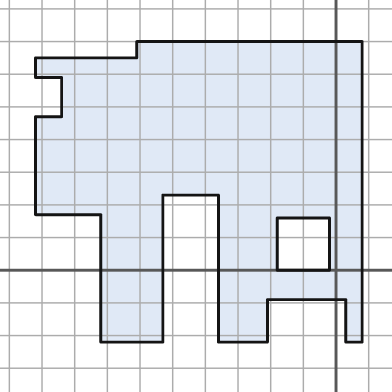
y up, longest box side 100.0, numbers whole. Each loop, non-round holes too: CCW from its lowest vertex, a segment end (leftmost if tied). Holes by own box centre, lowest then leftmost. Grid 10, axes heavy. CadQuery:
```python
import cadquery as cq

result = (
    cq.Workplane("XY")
    .moveTo(-72.0, -22.0)
    .lineTo(-53.0, -22.0)
    .lineTo(-53.0, 23.0)
    .lineTo(-36.0, 23.0)
    .lineTo(-36.0, -22.0)
    .lineTo(-21.0, -22.0)
    .lineTo(-21.0, -9.0)
    .lineTo(3.0, -9.0)
    .lineTo(3.0, -22.0)
    .lineTo(8.0, -22.0)
    .lineTo(8.0, 70.0)
    .lineTo(-61.0, 70.0)
    .lineTo(-61.0, 65.0)
    .lineTo(-92.0, 65.0)
    .lineTo(-92.0, 59.0)
    .lineTo(-84.0, 59.0)
    .lineTo(-84.0, 47.0)
    .lineTo(-92.0, 47.0)
    .lineTo(-92.0, 17.0)
    .lineTo(-72.0, 17.0)
    .close()
    .moveTo(-18.0, 0.0)
    .lineTo(-2.0, 0.0)
    .lineTo(-2.0, 16.0)
    .lineTo(-18.0, 16.0)
    .close()
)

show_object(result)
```